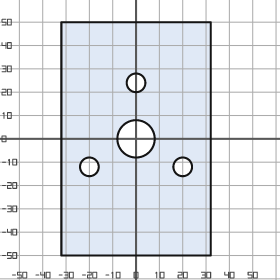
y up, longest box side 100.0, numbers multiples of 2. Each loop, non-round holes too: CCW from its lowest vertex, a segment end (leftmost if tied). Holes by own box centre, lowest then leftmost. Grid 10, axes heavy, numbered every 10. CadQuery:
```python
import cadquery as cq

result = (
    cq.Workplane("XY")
    .moveTo(-32.0, -50.0)
    .lineTo(32.0, -50.0)
    .lineTo(32.0, 50.0)
    .lineTo(-32.0, 50.0)
    .close()
    .moveTo(-20.0, -12.0)
    .circle(4.0)
    .moveTo(20.0, -12.0)
    .circle(4.0)
    .moveTo(0.0, 0.0)
    .circle(8.0)
    .moveTo(0.0, 24.0)
    .circle(4.0)
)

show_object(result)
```